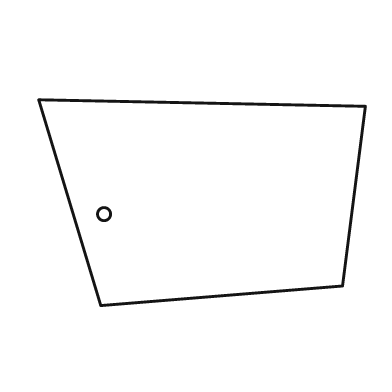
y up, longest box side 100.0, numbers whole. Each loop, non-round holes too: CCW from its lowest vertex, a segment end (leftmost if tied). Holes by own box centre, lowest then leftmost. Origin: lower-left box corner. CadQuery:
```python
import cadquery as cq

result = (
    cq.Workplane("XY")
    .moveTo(19.0, 0.0)
    .lineTo(93.0, 6.0)
    .lineTo(100.0, 61.0)
    .lineTo(0.0, 63.0)
    .close()
    .moveTo(20.0, 28.0)
    .circle(2.0)
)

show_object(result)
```